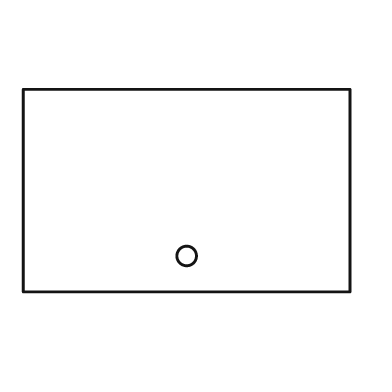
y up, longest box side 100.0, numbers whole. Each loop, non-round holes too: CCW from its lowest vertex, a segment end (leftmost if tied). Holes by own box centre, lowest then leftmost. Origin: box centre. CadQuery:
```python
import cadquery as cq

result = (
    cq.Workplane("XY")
    .moveTo(-50.0, -31.0)
    .lineTo(50.0, -31.0)
    .lineTo(50.0, 31.0)
    .lineTo(-50.0, 31.0)
    .close()
    .moveTo(0.0, -20.0)
    .circle(3.0)
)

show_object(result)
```